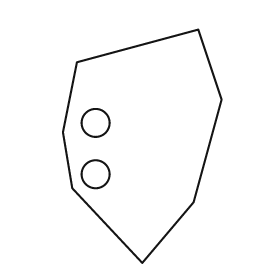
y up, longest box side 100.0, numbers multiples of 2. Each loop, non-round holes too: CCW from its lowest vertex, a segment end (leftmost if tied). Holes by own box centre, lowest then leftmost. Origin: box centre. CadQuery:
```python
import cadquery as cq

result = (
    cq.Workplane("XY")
    .moveTo(0.0, -50.0)
    .lineTo(22.0, -24.0)
    .lineTo(34.0, 20.0)
    .lineTo(24.0, 50.0)
    .lineTo(-28.0, 36.0)
    .lineTo(-34.0, 6.0)
    .lineTo(-30.0, -18.0)
    .close()
    .moveTo(-20.0, -12.0)
    .circle(6.0)
    .moveTo(-20.0, 10.0)
    .circle(6.0)
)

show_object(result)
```